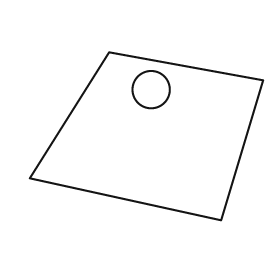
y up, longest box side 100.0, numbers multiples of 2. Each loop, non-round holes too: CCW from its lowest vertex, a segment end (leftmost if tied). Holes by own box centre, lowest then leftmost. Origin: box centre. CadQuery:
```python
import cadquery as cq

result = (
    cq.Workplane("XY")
    .moveTo(32.0, -36.0)
    .lineTo(50.0, 24.0)
    .lineTo(-16.0, 36.0)
    .lineTo(-50.0, -18.0)
    .close()
    .moveTo(2.0, 20.0)
    .circle(8.0)
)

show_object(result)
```